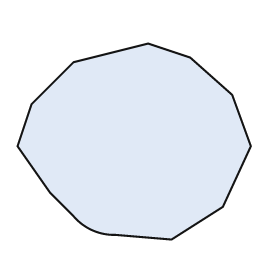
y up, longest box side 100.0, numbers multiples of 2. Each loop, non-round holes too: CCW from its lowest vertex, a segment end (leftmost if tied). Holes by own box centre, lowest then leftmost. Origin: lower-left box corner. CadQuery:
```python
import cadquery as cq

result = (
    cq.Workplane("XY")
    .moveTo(66.0, 0.0)
    .lineTo(88.0, 14.0)
    .lineTo(100.0, 40.0)
    .lineTo(92.0, 62.0)
    .lineTo(74.0, 78.0)
    .lineTo(56.0, 84.0)
    .lineTo(24.0, 76.0)
    .lineTo(6.0, 58.0)
    .lineTo(0.0, 40.0)
    .lineTo(14.0, 20.0)
    .lineTo(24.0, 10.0)
    .threePointArc((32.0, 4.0), (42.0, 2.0))
    .close()
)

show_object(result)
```